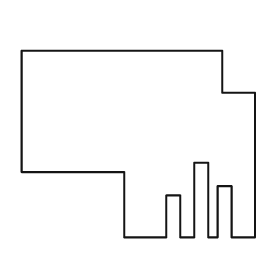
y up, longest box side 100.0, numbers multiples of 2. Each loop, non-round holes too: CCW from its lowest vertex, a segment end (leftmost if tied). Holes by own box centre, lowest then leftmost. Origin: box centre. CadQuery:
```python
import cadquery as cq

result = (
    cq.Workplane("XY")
    .moveTo(-6.0, -40.0)
    .lineTo(12.0, -40.0)
    .lineTo(12.0, -22.0)
    .lineTo(18.0, -22.0)
    .lineTo(18.0, -40.0)
    .lineTo(24.0, -40.0)
    .lineTo(24.0, -8.0)
    .lineTo(30.0, -8.0)
    .lineTo(30.0, -40.0)
    .lineTo(34.0, -40.0)
    .lineTo(34.0, -18.0)
    .lineTo(40.0, -18.0)
    .lineTo(40.0, -40.0)
    .lineTo(50.0, -40.0)
    .lineTo(50.0, 22.0)
    .lineTo(36.0, 22.0)
    .lineTo(36.0, 40.0)
    .lineTo(-50.0, 40.0)
    .lineTo(-50.0, -12.0)
    .lineTo(-6.0, -12.0)
    .close()
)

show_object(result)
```